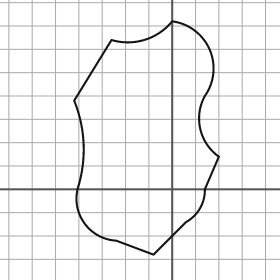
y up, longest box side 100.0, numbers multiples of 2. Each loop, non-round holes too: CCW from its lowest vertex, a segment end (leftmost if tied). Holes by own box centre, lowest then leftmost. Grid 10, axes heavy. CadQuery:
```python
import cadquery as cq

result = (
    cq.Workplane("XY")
    .moveTo(-8.0, -28.0)
    .lineTo(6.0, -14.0)
    .threePointArc((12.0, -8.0), (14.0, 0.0))
    .lineTo(20.0, 14.0)
    .threePointArc((12.0, 26.0), (14.0, 40.0))
    .threePointArc((16.0, 60.0), (0.0, 72.0))
    .threePointArc((-12.0, 64.0), (-26.0, 64.0))
    .lineTo(-42.0, 38.0)
    .threePointArc((-38.0, 20.0), (-40.0, 2.0))
    .threePointArc((-38.0, -14.0), (-24.0, -22.0))
    .close()
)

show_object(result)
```